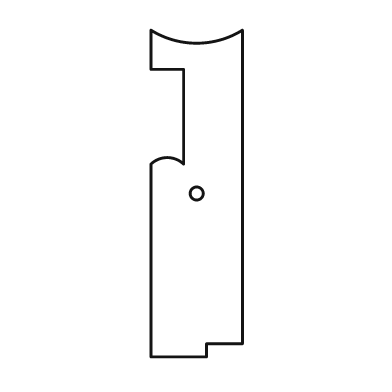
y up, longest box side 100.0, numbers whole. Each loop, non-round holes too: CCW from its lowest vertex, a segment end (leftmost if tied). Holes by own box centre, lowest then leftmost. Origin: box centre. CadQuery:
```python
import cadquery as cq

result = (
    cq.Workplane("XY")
    .moveTo(-14.0, -50.0)
    .lineTo(3.0, -50.0)
    .lineTo(3.0, -46.0)
    .lineTo(14.0, -46.0)
    .lineTo(14.0, 50.0)
    .threePointArc((0.0, 46.0), (-14.0, 50.0))
    .lineTo(-14.0, 38.0)
    .lineTo(-4.0, 38.0)
    .lineTo(-4.0, 9.0)
    .threePointArc((-9.0, 11.0), (-14.0, 9.0))
    .close()
    .moveTo(0.0, 0.0)
    .circle(2.0)
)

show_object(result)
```